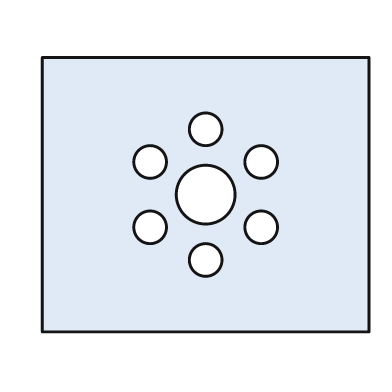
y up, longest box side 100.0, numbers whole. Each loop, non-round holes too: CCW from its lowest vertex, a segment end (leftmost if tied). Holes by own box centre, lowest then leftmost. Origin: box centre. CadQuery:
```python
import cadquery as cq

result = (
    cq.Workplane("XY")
    .moveTo(-50.0, -42.0)
    .lineTo(50.0, -42.0)
    .lineTo(50.0, 42.0)
    .lineTo(-50.0, 42.0)
    .close()
    .moveTo(0.0, -20.0)
    .circle(5.0)
    .moveTo(-17.0, -10.0)
    .circle(5.0)
    .moveTo(17.0, -10.0)
    .circle(5.0)
    .moveTo(0.0, 0.0)
    .circle(9.0)
    .moveTo(-17.0, 10.0)
    .circle(5.0)
    .moveTo(17.0, 10.0)
    .circle(5.0)
    .moveTo(0.0, 20.0)
    .circle(5.0)
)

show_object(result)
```